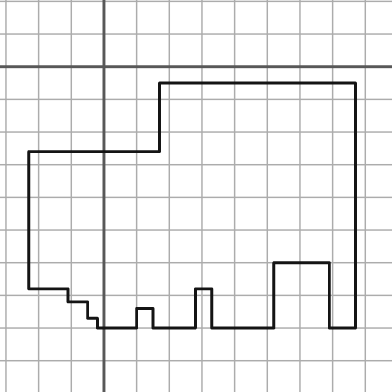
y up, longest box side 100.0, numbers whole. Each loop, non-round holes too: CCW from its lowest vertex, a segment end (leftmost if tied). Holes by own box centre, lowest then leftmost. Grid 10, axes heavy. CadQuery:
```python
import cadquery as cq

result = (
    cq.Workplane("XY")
    .moveTo(-2.0, -80.0)
    .lineTo(10.0, -80.0)
    .lineTo(10.0, -74.0)
    .lineTo(15.0, -74.0)
    .lineTo(15.0, -80.0)
    .lineTo(28.0, -80.0)
    .lineTo(28.0, -68.0)
    .lineTo(33.0, -68.0)
    .lineTo(33.0, -80.0)
    .lineTo(52.0, -80.0)
    .lineTo(52.0, -60.0)
    .lineTo(69.0, -60.0)
    .lineTo(69.0, -80.0)
    .lineTo(77.0, -80.0)
    .lineTo(77.0, -5.0)
    .lineTo(17.0, -5.0)
    .lineTo(17.0, -26.0)
    .lineTo(-23.0, -26.0)
    .lineTo(-23.0, -68.0)
    .lineTo(-11.0, -68.0)
    .lineTo(-11.0, -72.0)
    .lineTo(-5.0, -72.0)
    .lineTo(-5.0, -77.0)
    .lineTo(-2.0, -77.0)
    .close()
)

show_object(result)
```